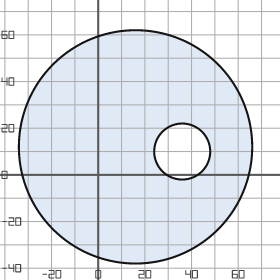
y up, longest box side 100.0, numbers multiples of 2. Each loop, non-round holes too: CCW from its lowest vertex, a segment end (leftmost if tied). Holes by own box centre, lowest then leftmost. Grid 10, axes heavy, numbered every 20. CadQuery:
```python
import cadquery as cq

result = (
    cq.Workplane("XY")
    .moveTo(16.0, 12.0)
    .circle(50.0)
    .moveTo(36.0, 10.0)
    .circle(12.0)
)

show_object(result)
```